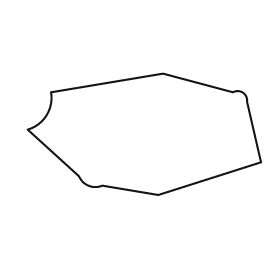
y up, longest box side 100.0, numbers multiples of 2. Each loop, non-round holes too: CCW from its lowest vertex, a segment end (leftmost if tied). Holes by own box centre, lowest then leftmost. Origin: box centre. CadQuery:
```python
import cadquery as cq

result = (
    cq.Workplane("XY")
    .moveTo(6.0, -26.0)
    .lineTo(50.0, -12.0)
    .lineTo(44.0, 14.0)
    .threePointArc((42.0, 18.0), (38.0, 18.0))
    .lineTo(8.0, 26.0)
    .lineTo(-40.0, 18.0)
    .threePointArc((-42.0, 8.0), (-50.0, 2.0))
    .lineTo(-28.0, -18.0)
    .threePointArc((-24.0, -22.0), (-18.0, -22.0))
    .close()
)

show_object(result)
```